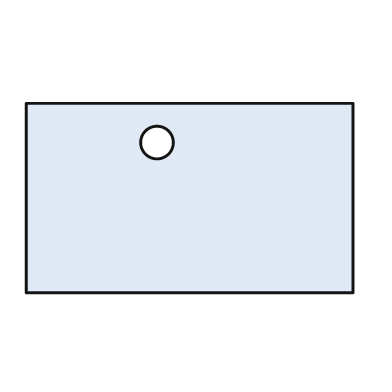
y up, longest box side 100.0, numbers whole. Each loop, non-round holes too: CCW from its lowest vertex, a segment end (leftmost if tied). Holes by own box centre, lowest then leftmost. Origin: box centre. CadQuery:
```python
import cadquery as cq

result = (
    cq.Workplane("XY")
    .moveTo(-50.0, -29.0)
    .lineTo(50.0, -29.0)
    .lineTo(50.0, 29.0)
    .lineTo(-50.0, 29.0)
    .close()
    .moveTo(-10.0, 17.0)
    .circle(5.0)
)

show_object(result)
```